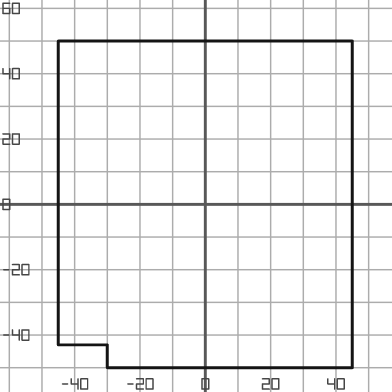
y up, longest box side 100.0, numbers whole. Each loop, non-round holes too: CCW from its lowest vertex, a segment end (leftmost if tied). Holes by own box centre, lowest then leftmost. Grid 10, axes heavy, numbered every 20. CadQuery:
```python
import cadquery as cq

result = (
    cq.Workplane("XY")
    .moveTo(-30.0, -50.0)
    .lineTo(45.0, -50.0)
    .lineTo(45.0, 50.0)
    .lineTo(-45.0, 50.0)
    .lineTo(-45.0, -43.0)
    .lineTo(-30.0, -43.0)
    .close()
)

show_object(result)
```